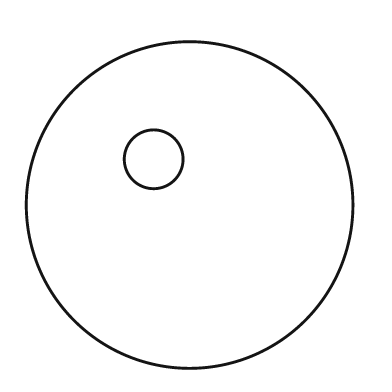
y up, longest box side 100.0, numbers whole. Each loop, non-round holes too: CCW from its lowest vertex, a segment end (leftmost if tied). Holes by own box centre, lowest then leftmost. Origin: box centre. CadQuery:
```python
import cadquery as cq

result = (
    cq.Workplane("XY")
    .moveTo(0.0, 0.0)
    .circle(50.0)
    .moveTo(-11.0, 14.0)
    .circle(9.0)
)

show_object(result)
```